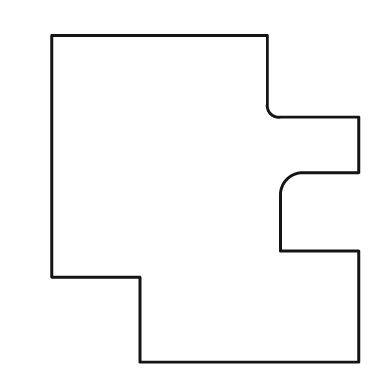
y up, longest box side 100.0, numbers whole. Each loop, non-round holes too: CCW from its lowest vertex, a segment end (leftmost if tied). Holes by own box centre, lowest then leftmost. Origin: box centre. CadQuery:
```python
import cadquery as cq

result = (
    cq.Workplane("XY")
    .moveTo(-20.0, -50.0)
    .lineTo(47.0, -50.0)
    .lineTo(47.0, -16.0)
    .lineTo(23.0, -16.0)
    .lineTo(23.0, 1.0)
    .threePointArc((25.0, 6.0), (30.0, 8.0))
    .lineTo(47.0, 8.0)
    .lineTo(47.0, 25.0)
    .lineTo(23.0, 25.0)
    .threePointArc((20.0, 26.0), (19.0, 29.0))
    .lineTo(19.0, 50.0)
    .lineTo(-47.0, 50.0)
    .lineTo(-47.0, -24.0)
    .lineTo(-20.0, -24.0)
    .close()
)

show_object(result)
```